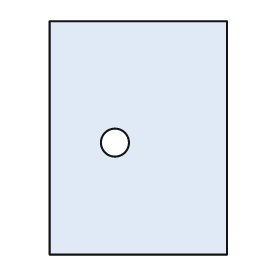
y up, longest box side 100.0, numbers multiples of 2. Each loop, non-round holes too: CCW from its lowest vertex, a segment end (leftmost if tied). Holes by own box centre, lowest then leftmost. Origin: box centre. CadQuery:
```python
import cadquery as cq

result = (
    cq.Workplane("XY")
    .moveTo(-38.0, -50.0)
    .lineTo(38.0, -50.0)
    .lineTo(38.0, 50.0)
    .lineTo(-38.0, 50.0)
    .close()
    .moveTo(-10.0, -2.0)
    .circle(6.0)
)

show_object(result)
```